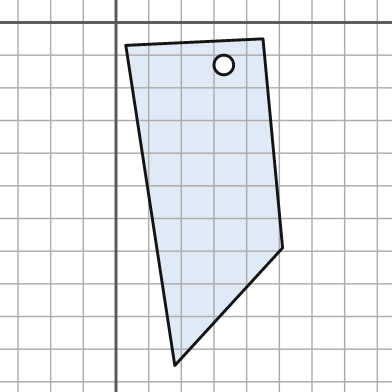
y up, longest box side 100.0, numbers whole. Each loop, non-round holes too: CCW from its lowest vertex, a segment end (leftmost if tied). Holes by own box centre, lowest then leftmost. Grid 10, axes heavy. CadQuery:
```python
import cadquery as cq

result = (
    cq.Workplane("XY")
    .moveTo(18.0, -105.0)
    .lineTo(51.0, -69.0)
    .lineTo(45.0, -5.0)
    .lineTo(3.0, -7.0)
    .close()
    .moveTo(33.0, -13.0)
    .circle(3.0)
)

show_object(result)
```